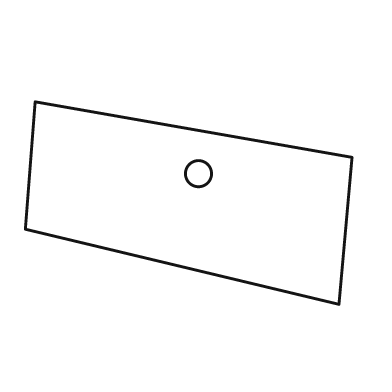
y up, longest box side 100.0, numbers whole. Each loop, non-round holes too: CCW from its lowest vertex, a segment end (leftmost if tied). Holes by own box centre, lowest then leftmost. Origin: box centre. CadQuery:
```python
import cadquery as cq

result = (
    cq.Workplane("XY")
    .moveTo(46.0, -31.0)
    .lineTo(50.0, 14.0)
    .lineTo(-47.0, 31.0)
    .lineTo(-50.0, -8.0)
    .close()
    .moveTo(3.0, 9.0)
    .circle(4.0)
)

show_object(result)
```